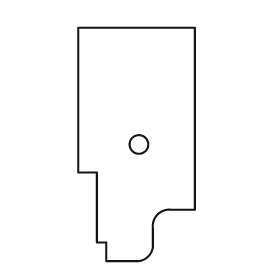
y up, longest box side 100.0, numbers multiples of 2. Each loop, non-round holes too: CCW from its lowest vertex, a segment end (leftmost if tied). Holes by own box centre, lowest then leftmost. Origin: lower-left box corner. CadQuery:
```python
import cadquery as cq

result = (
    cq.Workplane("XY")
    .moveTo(12.0, 0.0)
    .lineTo(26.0, 0.0)
    .threePointArc((30.0, 2.0), (32.0, 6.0))
    .lineTo(32.0, 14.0)
    .threePointArc((34.0, 20.0), (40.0, 22.0))
    .lineTo(50.0, 22.0)
    .lineTo(50.0, 100.0)
    .lineTo(0.0, 100.0)
    .lineTo(0.0, 38.0)
    .lineTo(8.0, 38.0)
    .lineTo(8.0, 8.0)
    .lineTo(12.0, 8.0)
    .close()
    .moveTo(26.0, 50.0)
    .circle(4.0)
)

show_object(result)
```